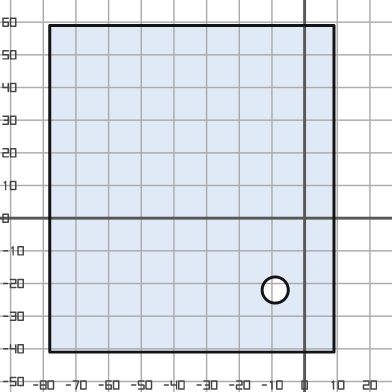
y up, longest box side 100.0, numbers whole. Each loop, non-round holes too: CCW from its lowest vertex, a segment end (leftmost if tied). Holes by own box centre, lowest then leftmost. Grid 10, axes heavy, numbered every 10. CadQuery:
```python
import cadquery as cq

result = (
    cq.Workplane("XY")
    .moveTo(-78.0, -41.0)
    .lineTo(9.0, -41.0)
    .lineTo(9.0, 59.0)
    .lineTo(-78.0, 59.0)
    .close()
    .moveTo(-9.0, -22.0)
    .circle(4.0)
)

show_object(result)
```